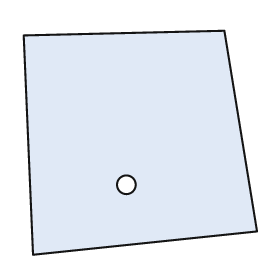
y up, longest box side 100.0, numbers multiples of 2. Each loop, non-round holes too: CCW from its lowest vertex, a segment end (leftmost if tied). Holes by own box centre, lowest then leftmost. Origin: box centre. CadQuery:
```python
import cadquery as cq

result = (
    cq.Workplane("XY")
    .moveTo(-46.0, -48.0)
    .lineTo(50.0, -38.0)
    .lineTo(36.0, 48.0)
    .lineTo(-50.0, 46.0)
    .close()
    .moveTo(-6.0, -18.0)
    .circle(4.0)
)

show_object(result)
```